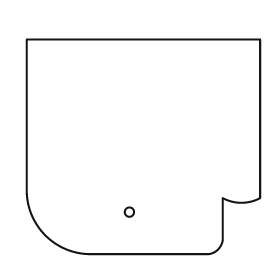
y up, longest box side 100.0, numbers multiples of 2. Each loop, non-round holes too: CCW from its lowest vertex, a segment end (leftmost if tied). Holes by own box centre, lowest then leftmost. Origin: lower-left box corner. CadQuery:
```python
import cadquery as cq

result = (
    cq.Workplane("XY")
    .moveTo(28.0, 0.0)
    .lineTo(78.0, 0.0)
    .threePointArc((82.0, 2.0), (84.0, 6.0))
    .lineTo(84.0, 24.0)
    .threePointArc((92.0, 22.0), (100.0, 24.0))
    .lineTo(100.0, 92.0)
    .lineTo(0.0, 92.0)
    .lineTo(0.0, 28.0)
    .threePointArc((8.0, 8.0), (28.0, 0.0))
    .close()
    .moveTo(44.0, 18.0)
    .circle(2.0)
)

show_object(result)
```